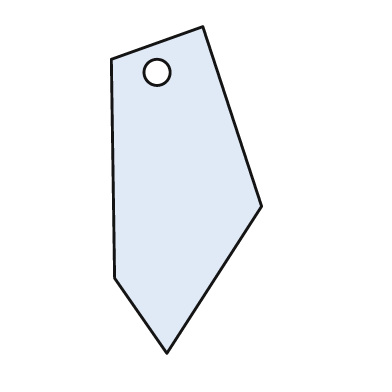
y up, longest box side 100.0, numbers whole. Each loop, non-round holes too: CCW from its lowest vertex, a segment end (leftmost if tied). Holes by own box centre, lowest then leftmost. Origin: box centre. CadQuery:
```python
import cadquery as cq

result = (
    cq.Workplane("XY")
    .moveTo(-6.0, -50.0)
    .lineTo(23.0, -5.0)
    .lineTo(5.0, 50.0)
    .lineTo(-23.0, 40.0)
    .lineTo(-22.0, -27.0)
    .close()
    .moveTo(-9.0, 36.0)
    .circle(4.0)
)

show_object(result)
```